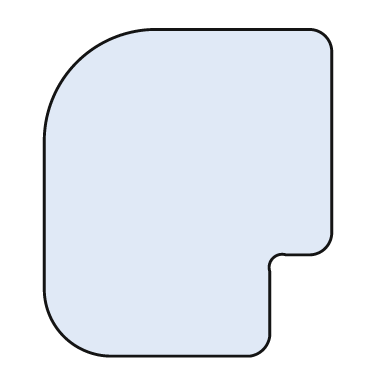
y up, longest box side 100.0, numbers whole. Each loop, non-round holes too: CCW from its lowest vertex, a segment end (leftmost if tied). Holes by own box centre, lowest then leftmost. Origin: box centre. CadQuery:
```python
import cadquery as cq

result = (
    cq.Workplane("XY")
    .moveTo(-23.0, -50.0)
    .lineTo(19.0, -50.0)
    .threePointArc((23.0, -48.0), (25.0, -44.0))
    .lineTo(25.0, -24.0)
    .threePointArc((26.0, -20.0), (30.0, -19.0))
    .lineTo(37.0, -19.0)
    .threePointArc((42.0, -17.0), (44.0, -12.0))
    .lineTo(44.0, 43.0)
    .threePointArc((42.0, 48.0), (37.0, 50.0))
    .lineTo(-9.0, 50.0)
    .threePointArc((-34.0, 40.0), (-44.0, 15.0))
    .lineTo(-44.0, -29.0)
    .threePointArc((-38.0, -44.0), (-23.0, -50.0))
    .close()
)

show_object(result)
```